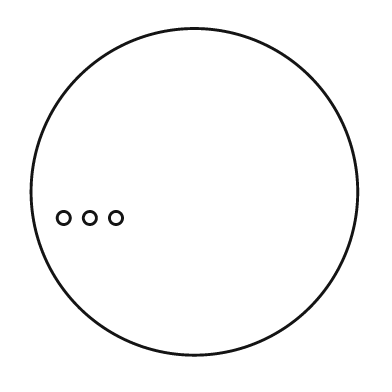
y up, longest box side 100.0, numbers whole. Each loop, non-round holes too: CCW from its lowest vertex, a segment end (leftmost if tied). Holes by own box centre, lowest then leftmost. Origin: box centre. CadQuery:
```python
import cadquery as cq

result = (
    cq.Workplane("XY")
    .moveTo(0.0, 0.0)
    .circle(50.0)
    .moveTo(-40.0, -8.0)
    .circle(2.0)
    .moveTo(-32.0, -8.0)
    .circle(2.0)
    .moveTo(-24.0, -8.0)
    .circle(2.0)
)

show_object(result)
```